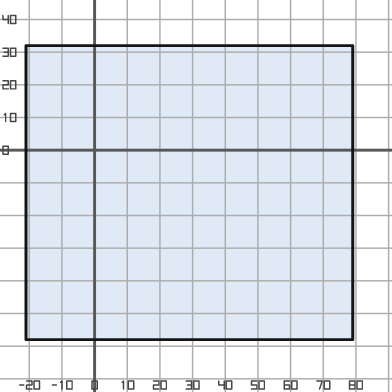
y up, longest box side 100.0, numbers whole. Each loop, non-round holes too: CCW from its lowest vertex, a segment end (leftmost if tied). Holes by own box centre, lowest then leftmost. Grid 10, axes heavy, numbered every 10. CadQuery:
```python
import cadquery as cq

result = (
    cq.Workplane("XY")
    .moveTo(-21.0, -58.0)
    .lineTo(79.0, -58.0)
    .lineTo(79.0, 32.0)
    .lineTo(-21.0, 32.0)
    .close()
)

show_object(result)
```